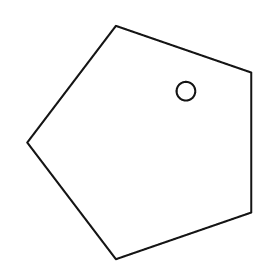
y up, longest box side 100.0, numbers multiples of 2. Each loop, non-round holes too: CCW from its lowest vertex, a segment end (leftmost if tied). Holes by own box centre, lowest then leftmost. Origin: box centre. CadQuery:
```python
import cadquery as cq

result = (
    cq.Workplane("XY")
    .moveTo(-10.0, -50.0)
    .lineTo(48.0, -30.0)
    .lineTo(48.0, 30.0)
    .lineTo(-10.0, 50.0)
    .lineTo(-48.0, 0.0)
    .close()
    .moveTo(20.0, 22.0)
    .circle(4.0)
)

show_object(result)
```